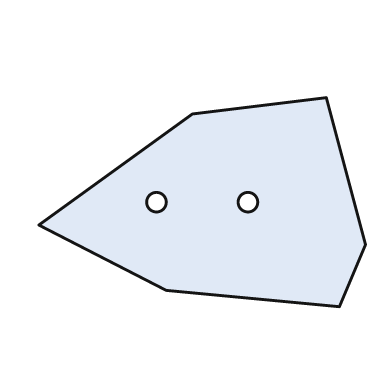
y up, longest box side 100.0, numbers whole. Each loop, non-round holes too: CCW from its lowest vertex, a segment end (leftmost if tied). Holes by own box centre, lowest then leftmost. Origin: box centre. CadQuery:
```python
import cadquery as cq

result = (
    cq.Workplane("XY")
    .moveTo(42.0, -32.0)
    .lineTo(50.0, -13.0)
    .lineTo(38.0, 32.0)
    .lineTo(-3.0, 27.0)
    .lineTo(-50.0, -7.0)
    .lineTo(-11.0, -27.0)
    .close()
    .moveTo(-14.0, 0.0)
    .circle(3.0)
    .moveTo(14.0, 0.0)
    .circle(3.0)
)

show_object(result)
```